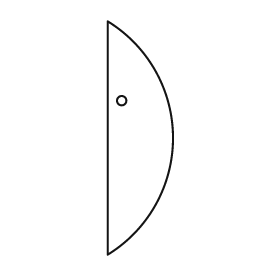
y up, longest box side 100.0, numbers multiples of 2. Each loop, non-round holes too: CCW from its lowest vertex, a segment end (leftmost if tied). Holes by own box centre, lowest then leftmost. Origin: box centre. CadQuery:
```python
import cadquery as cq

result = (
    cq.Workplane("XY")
    .moveTo(-14.0, -50.0)
    .threePointArc((14.0, 0.0), (-14.0, 50.0))
    .close()
    .moveTo(-8.0, 16.0)
    .circle(2.0)
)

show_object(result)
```